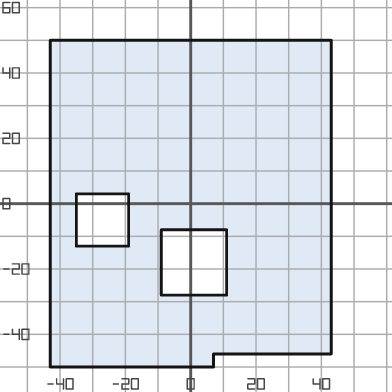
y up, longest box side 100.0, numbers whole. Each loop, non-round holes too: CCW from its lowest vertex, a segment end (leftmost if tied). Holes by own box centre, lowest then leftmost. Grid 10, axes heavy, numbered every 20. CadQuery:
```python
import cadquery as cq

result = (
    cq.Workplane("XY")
    .moveTo(-43.0, -50.0)
    .lineTo(7.0, -50.0)
    .lineTo(7.0, -46.0)
    .lineTo(43.0, -46.0)
    .lineTo(43.0, 50.0)
    .lineTo(-43.0, 50.0)
    .close()
    .moveTo(-9.0, -28.0)
    .lineTo(11.0, -28.0)
    .lineTo(11.0, -8.0)
    .lineTo(-9.0, -8.0)
    .close()
    .moveTo(-35.0, -13.0)
    .lineTo(-19.0, -13.0)
    .lineTo(-19.0, 3.0)
    .lineTo(-35.0, 3.0)
    .close()
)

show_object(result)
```